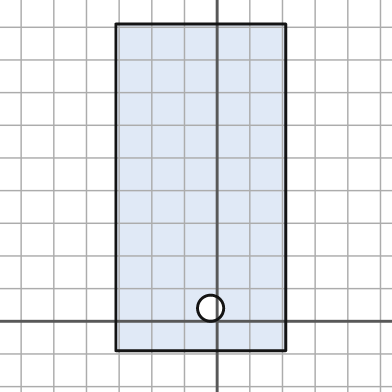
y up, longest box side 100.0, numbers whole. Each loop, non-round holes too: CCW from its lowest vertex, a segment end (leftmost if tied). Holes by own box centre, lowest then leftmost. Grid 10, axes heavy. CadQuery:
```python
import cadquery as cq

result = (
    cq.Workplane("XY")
    .moveTo(-31.0, -9.0)
    .lineTo(21.0, -9.0)
    .lineTo(21.0, 91.0)
    .lineTo(-31.0, 91.0)
    .close()
    .moveTo(-2.0, 4.0)
    .circle(4.0)
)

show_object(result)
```